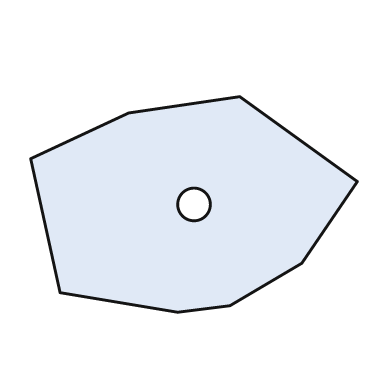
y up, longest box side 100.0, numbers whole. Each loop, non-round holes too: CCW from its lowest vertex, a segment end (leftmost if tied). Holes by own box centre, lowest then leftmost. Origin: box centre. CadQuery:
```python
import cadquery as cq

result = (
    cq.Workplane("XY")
    .moveTo(-5.0, -33.0)
    .lineTo(11.0, -31.0)
    .lineTo(33.0, -18.0)
    .lineTo(50.0, 7.0)
    .lineTo(14.0, 33.0)
    .lineTo(-20.0, 28.0)
    .lineTo(-50.0, 14.0)
    .lineTo(-41.0, -27.0)
    .close()
    .moveTo(0.0, 0.0)
    .circle(5.0)
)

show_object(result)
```